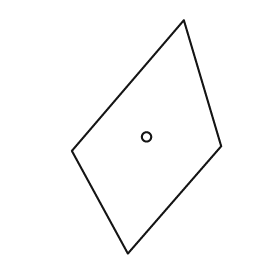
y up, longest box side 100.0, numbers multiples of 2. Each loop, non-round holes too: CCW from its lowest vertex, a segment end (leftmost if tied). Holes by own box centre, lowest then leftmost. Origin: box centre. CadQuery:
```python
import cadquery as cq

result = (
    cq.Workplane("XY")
    .moveTo(-8.0, -50.0)
    .lineTo(32.0, -4.0)
    .lineTo(16.0, 50.0)
    .lineTo(-32.0, -6.0)
    .close()
    .moveTo(0.0, 0.0)
    .circle(2.0)
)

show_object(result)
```